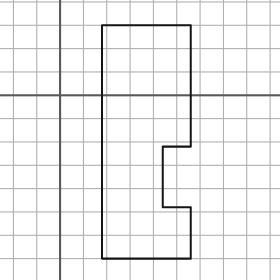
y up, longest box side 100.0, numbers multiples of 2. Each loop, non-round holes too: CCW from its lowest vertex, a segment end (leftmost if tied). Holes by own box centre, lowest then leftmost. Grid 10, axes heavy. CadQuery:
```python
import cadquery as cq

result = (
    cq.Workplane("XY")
    .moveTo(18.0, -70.0)
    .lineTo(56.0, -70.0)
    .lineTo(56.0, -48.0)
    .lineTo(44.0, -48.0)
    .lineTo(44.0, -22.0)
    .lineTo(56.0, -22.0)
    .lineTo(56.0, 30.0)
    .lineTo(18.0, 30.0)
    .close()
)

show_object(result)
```